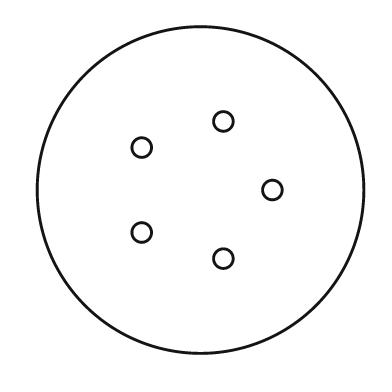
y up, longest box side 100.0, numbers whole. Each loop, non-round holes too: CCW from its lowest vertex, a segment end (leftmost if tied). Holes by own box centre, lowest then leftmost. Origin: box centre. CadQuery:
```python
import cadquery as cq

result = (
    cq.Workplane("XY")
    .moveTo(0.0, 0.0)
    .circle(50.0)
    .moveTo(7.0, -21.0)
    .circle(3.0)
    .moveTo(-18.0, -13.0)
    .circle(3.0)
    .moveTo(22.0, 0.0)
    .circle(3.0)
    .moveTo(-18.0, 13.0)
    .circle(3.0)
    .moveTo(7.0, 21.0)
    .circle(3.0)
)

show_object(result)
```